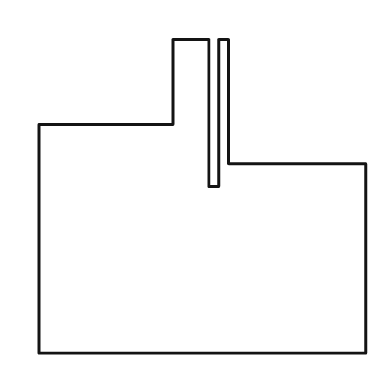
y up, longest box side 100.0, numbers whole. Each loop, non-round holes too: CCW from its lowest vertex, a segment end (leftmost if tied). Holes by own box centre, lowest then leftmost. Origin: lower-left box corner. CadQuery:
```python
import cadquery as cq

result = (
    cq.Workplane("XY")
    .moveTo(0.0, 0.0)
    .lineTo(100.0, 0.0)
    .lineTo(100.0, 58.0)
    .lineTo(58.0, 58.0)
    .lineTo(58.0, 96.0)
    .lineTo(55.0, 96.0)
    .lineTo(55.0, 51.0)
    .lineTo(52.0, 51.0)
    .lineTo(52.0, 96.0)
    .lineTo(41.0, 96.0)
    .lineTo(41.0, 70.0)
    .lineTo(0.0, 70.0)
    .close()
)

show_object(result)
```